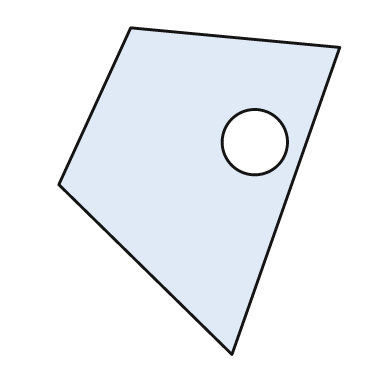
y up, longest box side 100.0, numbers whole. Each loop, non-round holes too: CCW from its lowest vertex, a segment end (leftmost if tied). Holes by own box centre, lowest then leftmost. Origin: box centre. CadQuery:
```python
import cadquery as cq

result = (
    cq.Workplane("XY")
    .moveTo(10.0, -50.0)
    .lineTo(43.0, 44.0)
    .lineTo(-21.0, 50.0)
    .lineTo(-43.0, 2.0)
    .close()
    .moveTo(17.0, 15.0)
    .circle(10.0)
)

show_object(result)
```